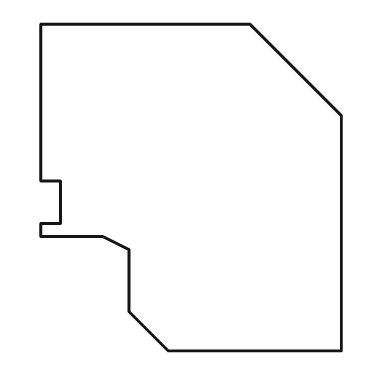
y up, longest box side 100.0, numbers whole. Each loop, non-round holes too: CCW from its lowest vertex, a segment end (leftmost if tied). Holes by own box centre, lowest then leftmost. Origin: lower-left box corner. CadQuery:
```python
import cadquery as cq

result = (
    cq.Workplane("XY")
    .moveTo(39.0, 0.0)
    .lineTo(92.0, 0.0)
    .lineTo(92.0, 72.0)
    .lineTo(64.0, 100.0)
    .lineTo(0.0, 100.0)
    .lineTo(0.0, 52.0)
    .lineTo(6.0, 52.0)
    .lineTo(6.0, 39.0)
    .lineTo(0.0, 39.0)
    .lineTo(0.0, 35.0)
    .lineTo(19.0, 35.0)
    .lineTo(27.0, 31.0)
    .lineTo(27.0, 12.0)
    .close()
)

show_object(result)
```